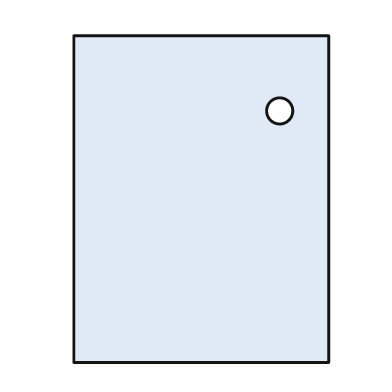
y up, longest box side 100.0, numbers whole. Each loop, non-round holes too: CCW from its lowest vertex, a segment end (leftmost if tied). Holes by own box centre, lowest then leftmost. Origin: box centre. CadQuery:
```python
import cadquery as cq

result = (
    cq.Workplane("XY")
    .moveTo(-39.0, -50.0)
    .lineTo(39.0, -50.0)
    .lineTo(39.0, 50.0)
    .lineTo(-39.0, 50.0)
    .close()
    .moveTo(24.0, 27.0)
    .circle(4.0)
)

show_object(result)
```